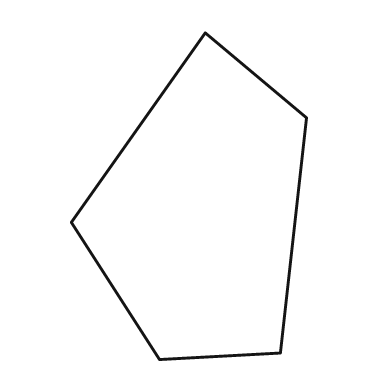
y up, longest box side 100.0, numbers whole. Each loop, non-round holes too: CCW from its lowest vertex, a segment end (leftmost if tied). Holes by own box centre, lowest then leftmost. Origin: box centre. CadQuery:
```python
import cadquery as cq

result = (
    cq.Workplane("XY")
    .moveTo(-9.0, -50.0)
    .lineTo(28.0, -48.0)
    .lineTo(36.0, 24.0)
    .lineTo(5.0, 50.0)
    .lineTo(-36.0, -8.0)
    .close()
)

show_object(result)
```